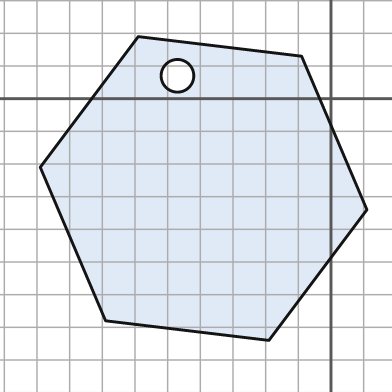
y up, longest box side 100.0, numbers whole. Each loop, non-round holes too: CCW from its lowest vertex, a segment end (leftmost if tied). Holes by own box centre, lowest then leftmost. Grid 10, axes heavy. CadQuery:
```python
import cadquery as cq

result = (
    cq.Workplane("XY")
    .moveTo(-19.0, -74.0)
    .lineTo(11.0, -34.0)
    .lineTo(-9.0, 13.0)
    .lineTo(-59.0, 19.0)
    .lineTo(-89.0, -21.0)
    .lineTo(-69.0, -68.0)
    .close()
    .moveTo(-47.0, 7.0)
    .circle(5.0)
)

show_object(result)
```